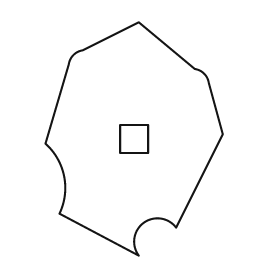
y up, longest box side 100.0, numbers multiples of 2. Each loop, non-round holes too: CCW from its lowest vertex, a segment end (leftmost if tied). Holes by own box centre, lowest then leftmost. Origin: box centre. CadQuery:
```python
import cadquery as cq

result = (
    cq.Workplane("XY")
    .moveTo(2.0, -50.0)
    .threePointArc((4.0, -36.0), (18.0, -38.0))
    .lineTo(38.0, 2.0)
    .lineTo(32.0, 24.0)
    .threePointArc((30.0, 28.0), (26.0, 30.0))
    .lineTo(2.0, 50.0)
    .lineTo(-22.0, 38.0)
    .threePointArc((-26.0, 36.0), (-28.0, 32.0))
    .lineTo(-38.0, -2.0)
    .threePointArc((-30.0, -16.0), (-32.0, -32.0))
    .close()
    .moveTo(-6.0, -6.0)
    .lineTo(6.0, -6.0)
    .lineTo(6.0, 6.0)
    .lineTo(-6.0, 6.0)
    .close()
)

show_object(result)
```